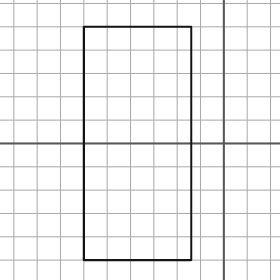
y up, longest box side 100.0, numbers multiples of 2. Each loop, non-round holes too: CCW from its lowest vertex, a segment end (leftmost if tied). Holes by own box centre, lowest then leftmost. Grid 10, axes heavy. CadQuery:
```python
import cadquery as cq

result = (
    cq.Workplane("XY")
    .moveTo(-60.0, -50.0)
    .lineTo(-14.0, -50.0)
    .lineTo(-14.0, 50.0)
    .lineTo(-60.0, 50.0)
    .close()
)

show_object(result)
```